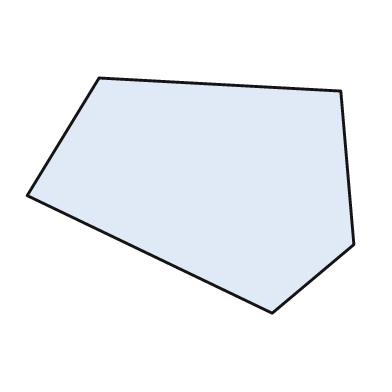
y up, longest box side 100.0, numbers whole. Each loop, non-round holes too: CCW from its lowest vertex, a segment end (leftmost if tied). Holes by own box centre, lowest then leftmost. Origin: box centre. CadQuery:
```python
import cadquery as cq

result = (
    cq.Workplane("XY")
    .moveTo(25.0, -36.0)
    .lineTo(50.0, -15.0)
    .lineTo(46.0, 32.0)
    .lineTo(-28.0, 36.0)
    .lineTo(-50.0, 0.0)
    .close()
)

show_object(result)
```